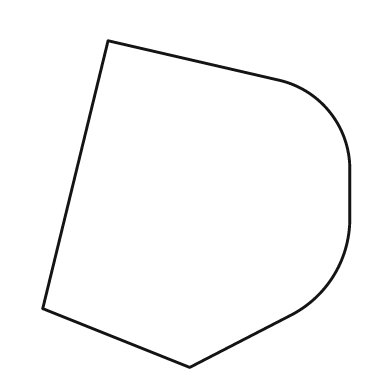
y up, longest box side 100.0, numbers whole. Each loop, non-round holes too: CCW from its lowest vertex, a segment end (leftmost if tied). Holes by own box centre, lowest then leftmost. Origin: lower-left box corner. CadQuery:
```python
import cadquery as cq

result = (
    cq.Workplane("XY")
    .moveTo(45.0, 0.0)
    .lineTo(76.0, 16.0)
    .threePointArc((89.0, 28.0), (94.0, 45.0))
    .lineTo(94.0, 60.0)
    .threePointArc((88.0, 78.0), (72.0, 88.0))
    .lineTo(20.0, 100.0)
    .lineTo(0.0, 18.0)
    .close()
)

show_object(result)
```